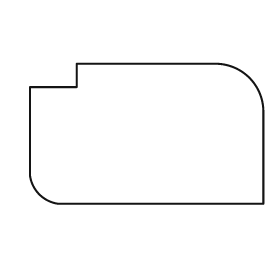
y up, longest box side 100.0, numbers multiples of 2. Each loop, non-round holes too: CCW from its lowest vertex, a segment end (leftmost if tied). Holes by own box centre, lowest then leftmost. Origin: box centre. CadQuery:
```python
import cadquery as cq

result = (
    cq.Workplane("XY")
    .moveTo(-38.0, -30.0)
    .lineTo(50.0, -30.0)
    .lineTo(50.0, 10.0)
    .threePointArc((44.0, 24.0), (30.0, 30.0))
    .lineTo(-30.0, 30.0)
    .lineTo(-30.0, 20.0)
    .lineTo(-50.0, 20.0)
    .lineTo(-50.0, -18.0)
    .threePointArc((-46.0, -26.0), (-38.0, -30.0))
    .close()
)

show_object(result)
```